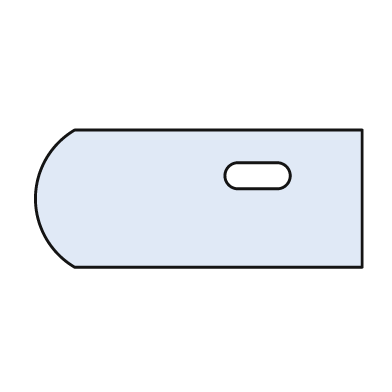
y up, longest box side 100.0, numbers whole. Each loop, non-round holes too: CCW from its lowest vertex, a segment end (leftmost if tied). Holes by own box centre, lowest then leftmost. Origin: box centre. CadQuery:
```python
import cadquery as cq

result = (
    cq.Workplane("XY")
    .moveTo(-38.0, -21.0)
    .lineTo(50.0, -21.0)
    .lineTo(50.0, 21.0)
    .lineTo(-38.0, 21.0)
    .threePointArc((-50.0, 0.0), (-38.0, -21.0))
    .close()
    .moveTo(12.0, 3.0)
    .lineTo(24.0, 3.0)
    .threePointArc((28.0, 7.0), (24.0, 11.0))
    .lineTo(12.0, 11.0)
    .threePointArc((8.0, 7.0), (12.0, 3.0))
    .close()
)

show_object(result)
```